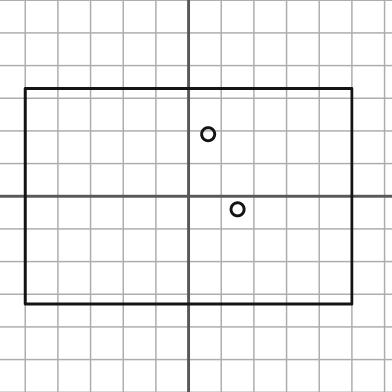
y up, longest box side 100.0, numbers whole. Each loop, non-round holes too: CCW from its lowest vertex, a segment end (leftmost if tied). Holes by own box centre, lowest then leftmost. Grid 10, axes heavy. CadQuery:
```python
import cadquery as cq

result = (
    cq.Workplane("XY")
    .moveTo(-50.0, -33.0)
    .lineTo(50.0, -33.0)
    .lineTo(50.0, 33.0)
    .lineTo(-50.0, 33.0)
    .close()
    .moveTo(15.0, -4.0)
    .circle(2.0)
    .moveTo(6.0, 19.0)
    .circle(2.0)
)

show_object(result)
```